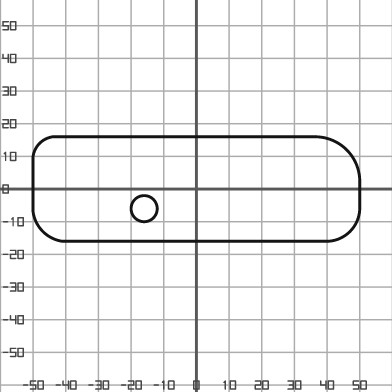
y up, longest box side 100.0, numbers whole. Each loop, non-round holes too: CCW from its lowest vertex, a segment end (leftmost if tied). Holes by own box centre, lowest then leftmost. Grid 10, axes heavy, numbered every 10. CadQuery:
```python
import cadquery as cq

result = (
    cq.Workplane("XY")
    .moveTo(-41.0, -16.0)
    .lineTo(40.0, -16.0)
    .threePointArc((47.0, -13.0), (50.0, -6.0))
    .lineTo(50.0, 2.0)
    .threePointArc((46.0, 12.0), (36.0, 16.0))
    .lineTo(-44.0, 16.0)
    .threePointArc((-48.0, 14.0), (-50.0, 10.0))
    .lineTo(-50.0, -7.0)
    .threePointArc((-47.0, -13.0), (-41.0, -16.0))
    .close()
    .moveTo(-16.0, -6.0)
    .circle(4.0)
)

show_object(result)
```